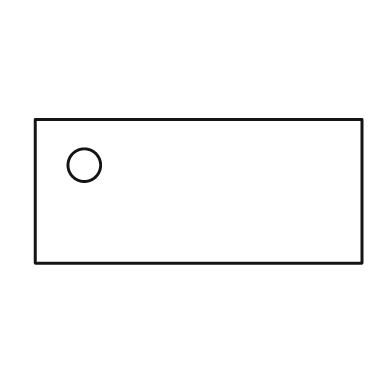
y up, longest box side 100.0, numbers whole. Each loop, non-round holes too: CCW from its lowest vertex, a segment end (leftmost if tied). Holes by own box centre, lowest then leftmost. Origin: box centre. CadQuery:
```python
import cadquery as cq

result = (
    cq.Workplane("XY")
    .moveTo(-50.0, -22.0)
    .lineTo(50.0, -22.0)
    .lineTo(50.0, 22.0)
    .lineTo(-50.0, 22.0)
    .close()
    .moveTo(-35.0, 8.0)
    .circle(5.0)
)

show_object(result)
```